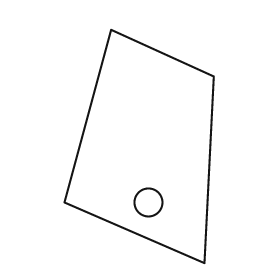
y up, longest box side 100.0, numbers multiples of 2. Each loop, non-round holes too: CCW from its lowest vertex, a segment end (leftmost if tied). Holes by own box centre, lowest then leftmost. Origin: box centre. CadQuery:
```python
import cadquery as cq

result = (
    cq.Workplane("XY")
    .moveTo(28.0, -50.0)
    .lineTo(32.0, 30.0)
    .lineTo(-12.0, 50.0)
    .lineTo(-32.0, -24.0)
    .close()
    .moveTo(4.0, -24.0)
    .circle(6.0)
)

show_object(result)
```